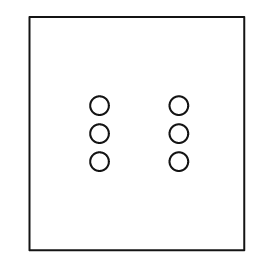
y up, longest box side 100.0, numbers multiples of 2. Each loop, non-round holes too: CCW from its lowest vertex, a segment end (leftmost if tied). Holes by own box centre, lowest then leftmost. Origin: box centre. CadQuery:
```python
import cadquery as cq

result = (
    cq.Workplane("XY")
    .moveTo(-46.0, -50.0)
    .lineTo(46.0, -50.0)
    .lineTo(46.0, 50.0)
    .lineTo(-46.0, 50.0)
    .close()
    .moveTo(-16.0, -12.0)
    .circle(4.0)
    .moveTo(18.0, -12.0)
    .circle(4.0)
    .moveTo(-16.0, 0.0)
    .circle(4.0)
    .moveTo(18.0, 0.0)
    .circle(4.0)
    .moveTo(-16.0, 12.0)
    .circle(4.0)
    .moveTo(18.0, 12.0)
    .circle(4.0)
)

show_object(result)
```